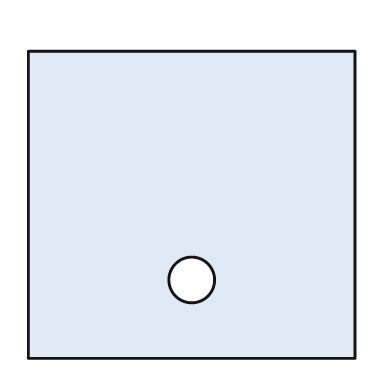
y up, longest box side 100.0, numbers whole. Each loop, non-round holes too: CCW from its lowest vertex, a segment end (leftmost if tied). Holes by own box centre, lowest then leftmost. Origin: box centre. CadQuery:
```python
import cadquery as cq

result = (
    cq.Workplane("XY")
    .moveTo(-50.0, -47.0)
    .lineTo(50.0, -47.0)
    .lineTo(50.0, 47.0)
    .lineTo(-50.0, 47.0)
    .close()
    .moveTo(0.0, -23.0)
    .circle(7.0)
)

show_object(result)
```